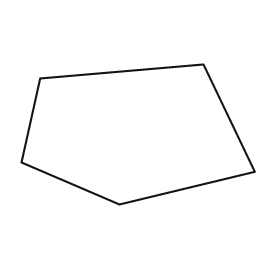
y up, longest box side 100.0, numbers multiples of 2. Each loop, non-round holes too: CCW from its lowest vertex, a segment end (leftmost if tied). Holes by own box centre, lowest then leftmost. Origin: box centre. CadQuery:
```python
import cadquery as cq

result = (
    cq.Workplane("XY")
    .moveTo(-8.0, -30.0)
    .lineTo(50.0, -16.0)
    .lineTo(28.0, 30.0)
    .lineTo(-42.0, 24.0)
    .lineTo(-50.0, -12.0)
    .close()
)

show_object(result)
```